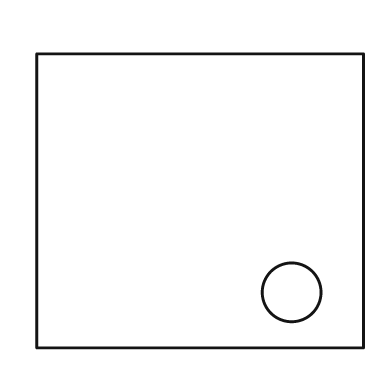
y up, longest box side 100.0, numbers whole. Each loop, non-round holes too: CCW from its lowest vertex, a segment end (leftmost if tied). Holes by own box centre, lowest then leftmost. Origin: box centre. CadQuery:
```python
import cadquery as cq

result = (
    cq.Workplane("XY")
    .moveTo(-50.0, -45.0)
    .lineTo(50.0, -45.0)
    .lineTo(50.0, 45.0)
    .lineTo(-50.0, 45.0)
    .close()
    .moveTo(28.0, -28.0)
    .circle(9.0)
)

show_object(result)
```